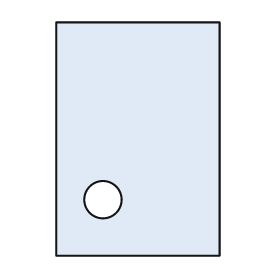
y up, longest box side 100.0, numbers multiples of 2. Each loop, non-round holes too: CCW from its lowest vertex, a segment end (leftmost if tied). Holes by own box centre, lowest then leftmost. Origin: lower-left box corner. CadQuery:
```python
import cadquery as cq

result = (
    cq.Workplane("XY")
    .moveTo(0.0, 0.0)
    .lineTo(70.0, 0.0)
    .lineTo(70.0, 100.0)
    .lineTo(0.0, 100.0)
    .close()
    .moveTo(20.0, 24.0)
    .circle(8.0)
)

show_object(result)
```